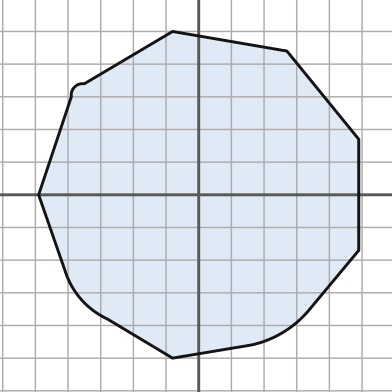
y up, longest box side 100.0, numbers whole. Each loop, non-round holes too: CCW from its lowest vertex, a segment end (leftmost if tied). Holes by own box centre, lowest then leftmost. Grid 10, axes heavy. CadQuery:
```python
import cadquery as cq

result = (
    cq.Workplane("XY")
    .moveTo(-8.0, -50.0)
    .lineTo(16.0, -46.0)
    .threePointArc((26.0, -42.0), (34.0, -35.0))
    .lineTo(49.0, -17.0)
    .lineTo(49.0, 17.0)
    .lineTo(27.0, 44.0)
    .lineTo(-8.0, 50.0)
    .lineTo(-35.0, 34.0)
    .threePointArc((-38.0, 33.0), (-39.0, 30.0))
    .lineTo(-49.0, 0.0)
    .lineTo(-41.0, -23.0)
    .threePointArc((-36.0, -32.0), (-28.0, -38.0))
    .close()
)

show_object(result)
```